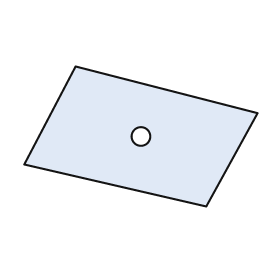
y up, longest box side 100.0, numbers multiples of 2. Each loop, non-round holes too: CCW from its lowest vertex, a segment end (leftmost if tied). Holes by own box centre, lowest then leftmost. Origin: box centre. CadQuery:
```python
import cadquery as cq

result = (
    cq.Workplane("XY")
    .moveTo(28.0, -30.0)
    .lineTo(50.0, 10.0)
    .lineTo(-28.0, 30.0)
    .lineTo(-50.0, -12.0)
    .close()
    .moveTo(0.0, 0.0)
    .circle(4.0)
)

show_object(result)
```